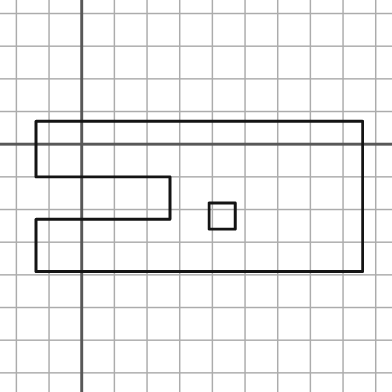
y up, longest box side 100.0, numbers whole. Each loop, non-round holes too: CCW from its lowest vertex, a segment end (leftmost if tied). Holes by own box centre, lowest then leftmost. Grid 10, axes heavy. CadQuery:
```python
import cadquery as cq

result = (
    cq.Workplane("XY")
    .moveTo(-14.0, -39.0)
    .lineTo(86.0, -39.0)
    .lineTo(86.0, 7.0)
    .lineTo(-14.0, 7.0)
    .lineTo(-14.0, -10.0)
    .lineTo(27.0, -10.0)
    .lineTo(27.0, -23.0)
    .lineTo(-14.0, -23.0)
    .close()
    .moveTo(39.0, -26.0)
    .lineTo(47.0, -26.0)
    .lineTo(47.0, -18.0)
    .lineTo(39.0, -18.0)
    .close()
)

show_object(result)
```